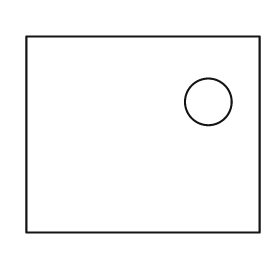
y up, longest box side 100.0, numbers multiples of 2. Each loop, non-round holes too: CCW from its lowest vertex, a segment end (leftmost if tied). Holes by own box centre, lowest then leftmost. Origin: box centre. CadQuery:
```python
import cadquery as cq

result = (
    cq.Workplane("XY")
    .moveTo(-50.0, -42.0)
    .lineTo(50.0, -42.0)
    .lineTo(50.0, 42.0)
    .lineTo(-50.0, 42.0)
    .close()
    .moveTo(28.0, 14.0)
    .circle(10.0)
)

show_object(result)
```